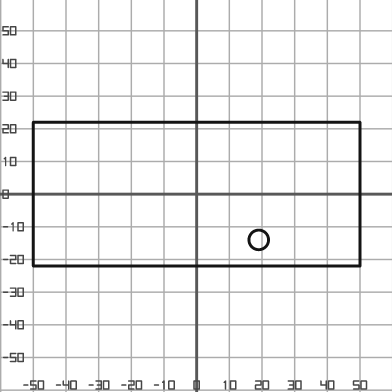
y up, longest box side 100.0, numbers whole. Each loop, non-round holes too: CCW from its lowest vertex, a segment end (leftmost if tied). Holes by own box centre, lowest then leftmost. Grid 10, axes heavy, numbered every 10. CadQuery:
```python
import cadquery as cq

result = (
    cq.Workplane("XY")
    .moveTo(-50.0, -22.0)
    .lineTo(50.0, -22.0)
    .lineTo(50.0, 22.0)
    .lineTo(-50.0, 22.0)
    .close()
    .moveTo(19.0, -14.0)
    .circle(3.0)
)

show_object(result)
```